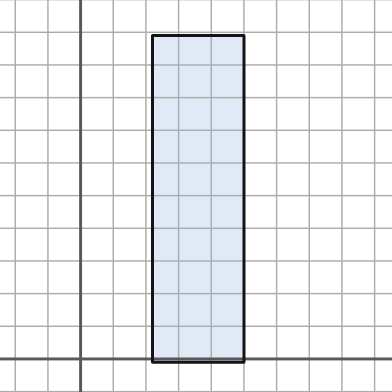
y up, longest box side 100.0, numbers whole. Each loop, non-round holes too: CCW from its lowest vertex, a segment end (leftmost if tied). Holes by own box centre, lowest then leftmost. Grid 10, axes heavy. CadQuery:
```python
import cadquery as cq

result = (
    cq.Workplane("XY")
    .moveTo(22.0, -1.0)
    .lineTo(50.0, -1.0)
    .lineTo(50.0, 99.0)
    .lineTo(22.0, 99.0)
    .close()
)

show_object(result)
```